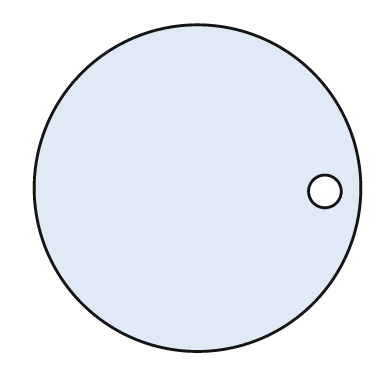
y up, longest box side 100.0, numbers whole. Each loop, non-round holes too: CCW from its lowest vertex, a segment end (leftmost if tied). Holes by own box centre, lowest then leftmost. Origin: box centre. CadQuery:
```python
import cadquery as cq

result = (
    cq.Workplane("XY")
    .moveTo(0.0, 0.0)
    .circle(50.0)
    .moveTo(39.0, -1.0)
    .circle(5.0)
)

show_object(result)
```